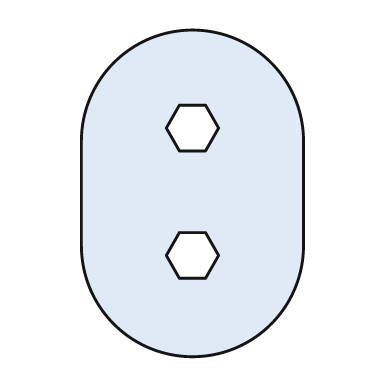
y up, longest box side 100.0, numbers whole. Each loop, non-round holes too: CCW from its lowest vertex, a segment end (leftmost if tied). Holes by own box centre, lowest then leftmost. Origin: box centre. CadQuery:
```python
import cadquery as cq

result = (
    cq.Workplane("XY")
    .moveTo(-34.0, -16.0)
    .threePointArc((0.0, -50.0), (34.0, -16.0))
    .lineTo(34.0, 16.0)
    .threePointArc((0.0, 50.0), (-34.0, 16.0))
    .close()
    .moveTo(-4.0, -26.0)
    .lineTo(4.0, -26.0)
    .lineTo(8.0, -19.0)
    .lineTo(4.0, -12.0)
    .lineTo(-4.0, -12.0)
    .lineTo(-8.0, -19.0)
    .close()
    .moveTo(-4.0, 13.0)
    .lineTo(4.0, 13.0)
    .lineTo(8.0, 20.0)
    .lineTo(4.0, 27.0)
    .lineTo(-4.0, 27.0)
    .lineTo(-8.0, 20.0)
    .close()
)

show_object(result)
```